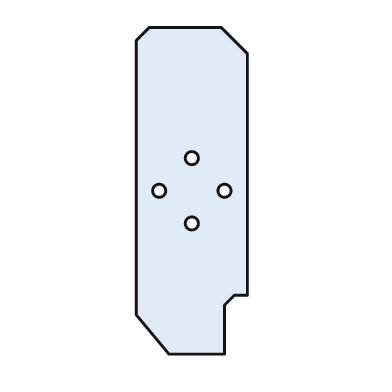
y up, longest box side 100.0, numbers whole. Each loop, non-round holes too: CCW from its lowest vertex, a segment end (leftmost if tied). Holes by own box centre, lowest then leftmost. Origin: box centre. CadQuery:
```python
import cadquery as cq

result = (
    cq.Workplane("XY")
    .moveTo(-7.0, -50.0)
    .lineTo(10.0, -50.0)
    .lineTo(10.0, -35.0)
    .lineTo(13.0, -32.0)
    .lineTo(17.0, -32.0)
    .lineTo(17.0, 42.0)
    .lineTo(9.0, 50.0)
    .lineTo(-13.0, 50.0)
    .lineTo(-17.0, 46.0)
    .lineTo(-17.0, -38.0)
    .close()
    .moveTo(0.0, -10.0)
    .circle(2.0)
    .moveTo(-10.0, 0.0)
    .circle(2.0)
    .moveTo(10.0, 0.0)
    .circle(2.0)
    .moveTo(0.0, 10.0)
    .circle(2.0)
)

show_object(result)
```